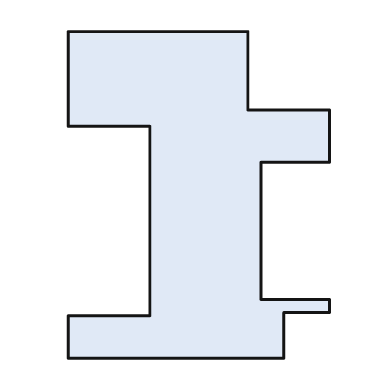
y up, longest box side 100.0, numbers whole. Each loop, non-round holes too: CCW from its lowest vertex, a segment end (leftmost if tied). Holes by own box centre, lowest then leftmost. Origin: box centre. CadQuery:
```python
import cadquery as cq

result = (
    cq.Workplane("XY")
    .moveTo(-40.0, -50.0)
    .lineTo(26.0, -50.0)
    .lineTo(26.0, -36.0)
    .lineTo(40.0, -36.0)
    .lineTo(40.0, -32.0)
    .lineTo(19.0, -32.0)
    .lineTo(19.0, 10.0)
    .lineTo(40.0, 10.0)
    .lineTo(40.0, 26.0)
    .lineTo(15.0, 26.0)
    .lineTo(15.0, 50.0)
    .lineTo(-40.0, 50.0)
    .lineTo(-40.0, 21.0)
    .lineTo(-15.0, 21.0)
    .lineTo(-15.0, -37.0)
    .lineTo(-40.0, -37.0)
    .close()
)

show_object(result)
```